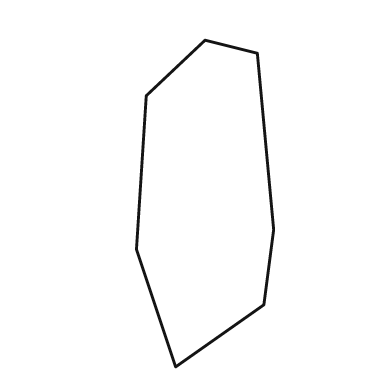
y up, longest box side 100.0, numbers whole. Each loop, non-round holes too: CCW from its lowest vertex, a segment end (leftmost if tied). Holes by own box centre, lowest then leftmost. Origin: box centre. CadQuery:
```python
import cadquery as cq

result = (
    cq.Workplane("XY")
    .moveTo(-9.0, -50.0)
    .lineTo(18.0, -31.0)
    .lineTo(21.0, -8.0)
    .lineTo(16.0, 46.0)
    .lineTo(0.0, 50.0)
    .lineTo(-18.0, 33.0)
    .lineTo(-21.0, -14.0)
    .close()
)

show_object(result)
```